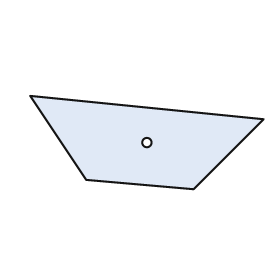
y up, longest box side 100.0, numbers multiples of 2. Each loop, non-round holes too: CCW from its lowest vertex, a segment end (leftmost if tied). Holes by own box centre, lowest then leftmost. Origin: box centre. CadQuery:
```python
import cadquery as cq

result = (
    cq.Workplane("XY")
    .moveTo(20.0, -20.0)
    .lineTo(50.0, 10.0)
    .lineTo(-50.0, 20.0)
    .lineTo(-26.0, -16.0)
    .close()
    .moveTo(0.0, 0.0)
    .circle(2.0)
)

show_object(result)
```